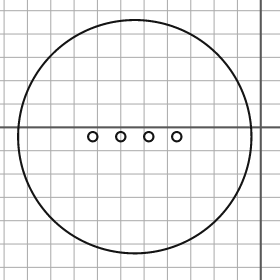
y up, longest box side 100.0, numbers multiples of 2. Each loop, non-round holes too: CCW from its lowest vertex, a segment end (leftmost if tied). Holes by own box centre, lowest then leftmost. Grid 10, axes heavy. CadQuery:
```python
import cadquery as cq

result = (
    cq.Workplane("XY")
    .moveTo(-54.0, -4.0)
    .circle(50.0)
    .moveTo(-72.0, -4.0)
    .circle(2.0)
    .moveTo(-60.0, -4.0)
    .circle(2.0)
    .moveTo(-48.0, -4.0)
    .circle(2.0)
    .moveTo(-36.0, -4.0)
    .circle(2.0)
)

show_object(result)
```